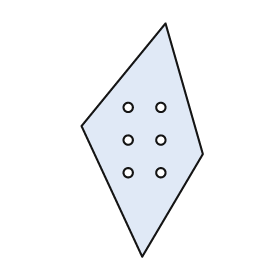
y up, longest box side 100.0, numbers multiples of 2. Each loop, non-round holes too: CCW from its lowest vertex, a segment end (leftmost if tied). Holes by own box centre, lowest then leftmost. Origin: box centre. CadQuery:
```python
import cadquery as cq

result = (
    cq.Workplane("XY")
    .moveTo(0.0, -50.0)
    .lineTo(26.0, -6.0)
    .lineTo(10.0, 50.0)
    .lineTo(-26.0, 6.0)
    .close()
    .moveTo(-6.0, -14.0)
    .circle(2.0)
    .moveTo(8.0, -14.0)
    .circle(2.0)
    .moveTo(-6.0, 0.0)
    .circle(2.0)
    .moveTo(8.0, 0.0)
    .circle(2.0)
    .moveTo(-6.0, 14.0)
    .circle(2.0)
    .moveTo(8.0, 14.0)
    .circle(2.0)
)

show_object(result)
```